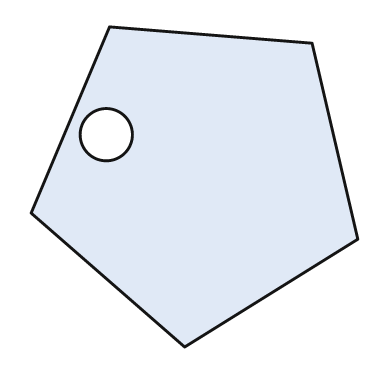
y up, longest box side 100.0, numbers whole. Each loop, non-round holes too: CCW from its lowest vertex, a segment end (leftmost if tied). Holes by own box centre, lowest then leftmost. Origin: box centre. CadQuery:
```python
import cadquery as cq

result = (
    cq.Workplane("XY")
    .moveTo(-3.0, -49.0)
    .lineTo(50.0, -16.0)
    .lineTo(36.0, 44.0)
    .lineTo(-26.0, 49.0)
    .lineTo(-50.0, -8.0)
    .close()
    .moveTo(-27.0, 16.0)
    .circle(8.0)
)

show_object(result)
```